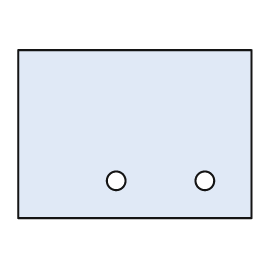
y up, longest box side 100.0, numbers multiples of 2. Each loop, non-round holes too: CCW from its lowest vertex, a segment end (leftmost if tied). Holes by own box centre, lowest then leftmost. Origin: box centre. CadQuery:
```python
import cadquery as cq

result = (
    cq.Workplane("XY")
    .moveTo(-50.0, -36.0)
    .lineTo(50.0, -36.0)
    .lineTo(50.0, 36.0)
    .lineTo(-50.0, 36.0)
    .close()
    .moveTo(-8.0, -20.0)
    .circle(4.0)
    .moveTo(30.0, -20.0)
    .circle(4.0)
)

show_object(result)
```